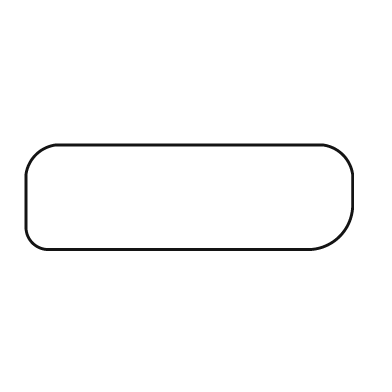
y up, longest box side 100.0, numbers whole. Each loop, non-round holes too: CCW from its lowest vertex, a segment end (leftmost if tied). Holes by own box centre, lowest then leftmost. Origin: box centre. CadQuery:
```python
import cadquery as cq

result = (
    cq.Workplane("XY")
    .moveTo(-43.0, -16.0)
    .lineTo(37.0, -16.0)
    .threePointArc((46.0, -12.0), (50.0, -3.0))
    .lineTo(50.0, 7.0)
    .threePointArc((47.0, 13.0), (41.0, 16.0))
    .lineTo(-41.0, 16.0)
    .threePointArc((-47.0, 13.0), (-50.0, 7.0))
    .lineTo(-50.0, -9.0)
    .threePointArc((-48.0, -14.0), (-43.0, -16.0))
    .close()
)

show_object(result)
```